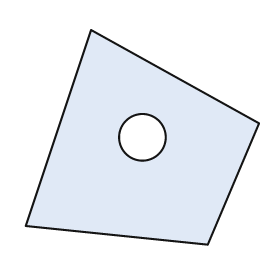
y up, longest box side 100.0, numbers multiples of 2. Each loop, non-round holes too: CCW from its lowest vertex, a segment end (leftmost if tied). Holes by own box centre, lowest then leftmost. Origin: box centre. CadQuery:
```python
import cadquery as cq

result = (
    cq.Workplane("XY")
    .moveTo(28.0, -46.0)
    .lineTo(50.0, 6.0)
    .lineTo(-22.0, 46.0)
    .lineTo(-50.0, -38.0)
    .close()
    .moveTo(0.0, 0.0)
    .circle(10.0)
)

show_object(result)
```